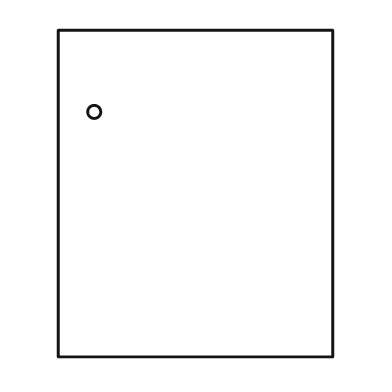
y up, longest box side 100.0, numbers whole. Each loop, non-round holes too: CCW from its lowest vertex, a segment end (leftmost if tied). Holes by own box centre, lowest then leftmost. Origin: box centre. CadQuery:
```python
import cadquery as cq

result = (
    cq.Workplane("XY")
    .moveTo(-42.0, -50.0)
    .lineTo(42.0, -50.0)
    .lineTo(42.0, 50.0)
    .lineTo(-42.0, 50.0)
    .close()
    .moveTo(-31.0, 25.0)
    .circle(2.0)
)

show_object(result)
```